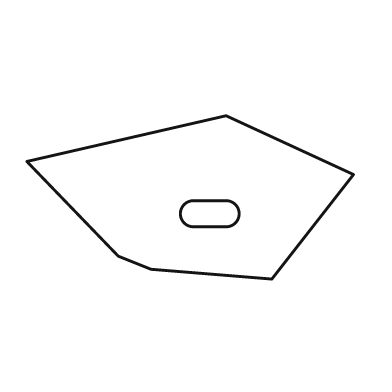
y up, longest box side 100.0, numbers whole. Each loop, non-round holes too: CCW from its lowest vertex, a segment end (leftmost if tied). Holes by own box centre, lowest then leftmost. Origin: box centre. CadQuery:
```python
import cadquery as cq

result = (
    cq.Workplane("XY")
    .moveTo(25.0, -25.0)
    .lineTo(50.0, 7.0)
    .lineTo(11.0, 25.0)
    .lineTo(-50.0, 11.0)
    .lineTo(-22.0, -18.0)
    .lineTo(-12.0, -22.0)
    .close()
    .moveTo(1.0, -9.0)
    .lineTo(11.0, -9.0)
    .threePointArc((15.0, -5.0), (11.0, -1.0))
    .lineTo(1.0, -1.0)
    .threePointArc((-3.0, -5.0), (1.0, -9.0))
    .close()
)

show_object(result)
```